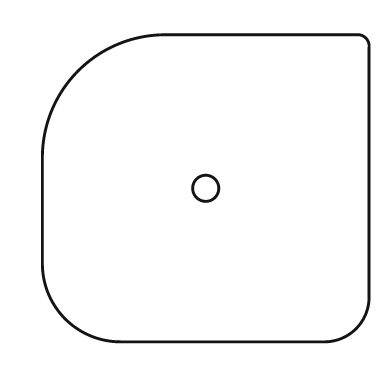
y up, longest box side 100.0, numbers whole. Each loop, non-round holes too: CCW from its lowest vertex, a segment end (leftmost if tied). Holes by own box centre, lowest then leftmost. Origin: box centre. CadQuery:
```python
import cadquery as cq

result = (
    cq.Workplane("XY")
    .moveTo(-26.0, -47.0)
    .lineTo(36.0, -47.0)
    .threePointArc((46.0, -43.0), (50.0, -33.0))
    .lineTo(50.0, 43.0)
    .threePointArc((49.0, 46.0), (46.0, 47.0))
    .lineTo(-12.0, 47.0)
    .threePointArc((-39.0, 36.0), (-50.0, 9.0))
    .lineTo(-50.0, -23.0)
    .threePointArc((-43.0, -40.0), (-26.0, -47.0))
    .close()
    .moveTo(0.0, 0.0)
    .circle(4.0)
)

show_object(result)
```